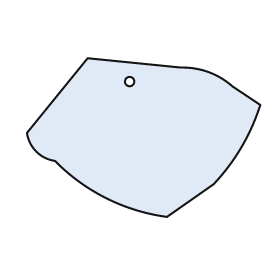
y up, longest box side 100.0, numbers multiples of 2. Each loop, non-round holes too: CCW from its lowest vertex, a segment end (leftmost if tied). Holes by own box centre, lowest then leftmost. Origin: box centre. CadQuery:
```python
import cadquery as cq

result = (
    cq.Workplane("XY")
    .moveTo(10.0, -34.0)
    .lineTo(30.0, -20.0)
    .threePointArc((42.0, -4.0), (50.0, 14.0))
    .lineTo(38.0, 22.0)
    .threePointArc((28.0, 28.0), (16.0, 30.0))
    .lineTo(-24.0, 34.0)
    .lineTo(-50.0, 2.0)
    .threePointArc((-46.0, -6.0), (-38.0, -10.0))
    .threePointArc((-16.0, -26.0), (10.0, -34.0))
    .close()
    .moveTo(-6.0, 24.0)
    .circle(2.0)
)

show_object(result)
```